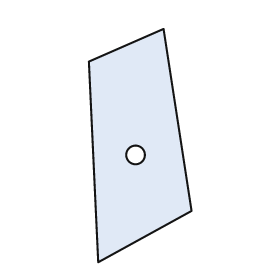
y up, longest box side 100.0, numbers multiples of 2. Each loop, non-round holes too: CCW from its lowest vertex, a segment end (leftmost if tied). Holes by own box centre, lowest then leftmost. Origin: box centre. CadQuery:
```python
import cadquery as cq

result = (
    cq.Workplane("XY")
    .moveTo(-18.0, -50.0)
    .lineTo(22.0, -28.0)
    .lineTo(10.0, 50.0)
    .lineTo(-22.0, 36.0)
    .close()
    .moveTo(-2.0, -4.0)
    .circle(4.0)
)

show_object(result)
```